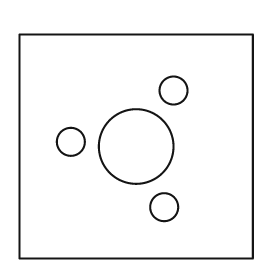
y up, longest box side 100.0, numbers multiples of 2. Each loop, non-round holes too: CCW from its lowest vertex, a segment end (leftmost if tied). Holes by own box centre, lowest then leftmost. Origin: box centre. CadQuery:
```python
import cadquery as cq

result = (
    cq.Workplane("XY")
    .moveTo(-50.0, -48.0)
    .lineTo(50.0, -48.0)
    .lineTo(50.0, 48.0)
    .lineTo(-50.0, 48.0)
    .close()
    .moveTo(12.0, -26.0)
    .circle(6.0)
    .moveTo(0.0, 0.0)
    .circle(16.0)
    .moveTo(-28.0, 2.0)
    .circle(6.0)
    .moveTo(16.0, 24.0)
    .circle(6.0)
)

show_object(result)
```